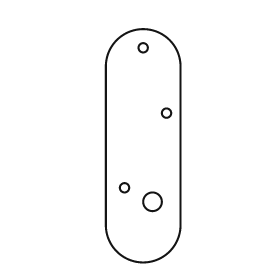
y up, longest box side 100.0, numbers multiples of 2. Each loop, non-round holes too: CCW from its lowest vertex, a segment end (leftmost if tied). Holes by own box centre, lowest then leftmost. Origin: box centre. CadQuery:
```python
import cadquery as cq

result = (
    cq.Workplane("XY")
    .moveTo(-16.0, -34.0)
    .threePointArc((0.0, -50.0), (16.0, -34.0))
    .lineTo(16.0, 34.0)
    .threePointArc((0.0, 50.0), (-16.0, 34.0))
    .close()
    .moveTo(4.0, -24.0)
    .circle(4.0)
    .moveTo(-8.0, -18.0)
    .circle(2.0)
    .moveTo(10.0, 14.0)
    .circle(2.0)
    .moveTo(0.0, 42.0)
    .circle(2.0)
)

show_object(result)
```